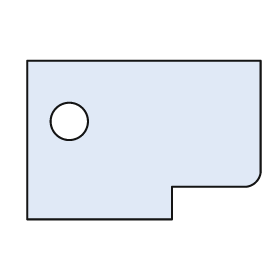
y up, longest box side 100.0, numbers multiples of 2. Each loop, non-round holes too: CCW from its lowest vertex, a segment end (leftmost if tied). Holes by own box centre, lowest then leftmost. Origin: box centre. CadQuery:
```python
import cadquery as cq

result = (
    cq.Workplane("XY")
    .moveTo(-50.0, -34.0)
    .lineTo(12.0, -34.0)
    .lineTo(12.0, -20.0)
    .lineTo(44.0, -20.0)
    .threePointArc((48.0, -18.0), (50.0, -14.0))
    .lineTo(50.0, 34.0)
    .lineTo(-50.0, 34.0)
    .close()
    .moveTo(-32.0, 8.0)
    .circle(8.0)
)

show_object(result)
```